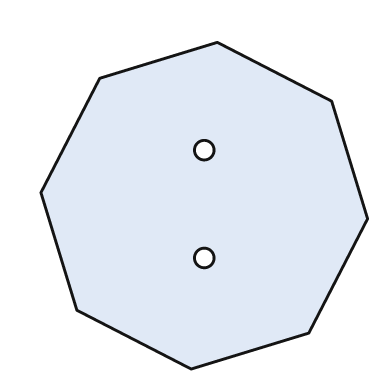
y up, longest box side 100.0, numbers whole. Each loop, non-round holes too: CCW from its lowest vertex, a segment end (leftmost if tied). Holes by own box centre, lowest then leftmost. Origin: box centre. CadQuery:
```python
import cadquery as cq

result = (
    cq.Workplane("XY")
    .moveTo(-4.0, -50.0)
    .lineTo(32.0, -39.0)
    .lineTo(50.0, -4.0)
    .lineTo(39.0, 32.0)
    .lineTo(4.0, 50.0)
    .lineTo(-32.0, 39.0)
    .lineTo(-50.0, 4.0)
    .lineTo(-39.0, -32.0)
    .close()
    .moveTo(0.0, -16.0)
    .circle(3.0)
    .moveTo(0.0, 17.0)
    .circle(3.0)
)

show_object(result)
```